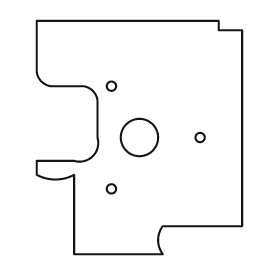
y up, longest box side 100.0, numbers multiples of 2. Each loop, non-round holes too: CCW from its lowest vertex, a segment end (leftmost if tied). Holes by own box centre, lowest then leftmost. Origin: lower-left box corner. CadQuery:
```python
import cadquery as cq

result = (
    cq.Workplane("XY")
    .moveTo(16.0, 0.0)
    .lineTo(54.0, 0.0)
    .threePointArc((52.0, 6.0), (54.0, 12.0))
    .lineTo(88.0, 12.0)
    .lineTo(88.0, 96.0)
    .lineTo(78.0, 96.0)
    .lineTo(78.0, 100.0)
    .lineTo(0.0, 100.0)
    .lineTo(0.0, 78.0)
    .threePointArc((2.0, 74.0), (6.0, 72.0))
    .lineTo(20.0, 72.0)
    .threePointArc((24.0, 70.0), (26.0, 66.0))
    .lineTo(26.0, 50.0)
    .threePointArc((24.0, 42.0), (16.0, 40.0))
    .lineTo(0.0, 40.0)
    .lineTo(0.0, 34.0)
    .threePointArc((8.0, 32.0), (16.0, 34.0))
    .close()
    .moveTo(32.0, 28.0)
    .circle(2.0)
    .moveTo(44.0, 50.0)
    .circle(8.0)
    .moveTo(70.0, 50.0)
    .circle(2.0)
    .moveTo(32.0, 72.0)
    .circle(2.0)
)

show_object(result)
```